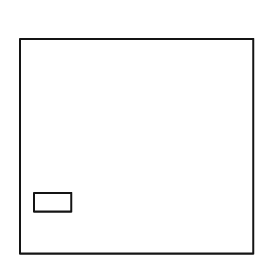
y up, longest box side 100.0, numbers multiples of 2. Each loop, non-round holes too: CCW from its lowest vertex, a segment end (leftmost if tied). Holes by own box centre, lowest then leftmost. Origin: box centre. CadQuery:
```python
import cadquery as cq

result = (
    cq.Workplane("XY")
    .moveTo(-50.0, -46.0)
    .lineTo(50.0, -46.0)
    .lineTo(50.0, 46.0)
    .lineTo(-50.0, 46.0)
    .close()
    .moveTo(-44.0, -28.0)
    .lineTo(-28.0, -28.0)
    .lineTo(-28.0, -20.0)
    .lineTo(-44.0, -20.0)
    .close()
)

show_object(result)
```